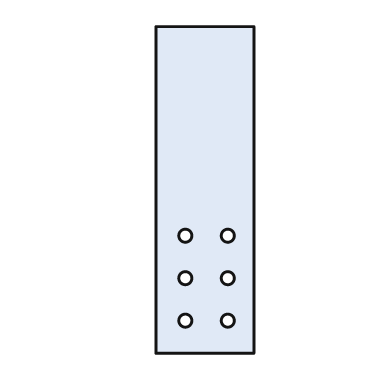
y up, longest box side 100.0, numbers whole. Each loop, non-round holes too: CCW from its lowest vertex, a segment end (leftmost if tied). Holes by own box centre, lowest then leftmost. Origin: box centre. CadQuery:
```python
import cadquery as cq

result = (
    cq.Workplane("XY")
    .moveTo(-15.0, -50.0)
    .lineTo(15.0, -50.0)
    .lineTo(15.0, 50.0)
    .lineTo(-15.0, 50.0)
    .close()
    .moveTo(-6.0, -40.0)
    .circle(2.0)
    .moveTo(7.0, -40.0)
    .circle(2.0)
    .moveTo(-6.0, -27.0)
    .circle(2.0)
    .moveTo(7.0, -27.0)
    .circle(2.0)
    .moveTo(-6.0, -14.0)
    .circle(2.0)
    .moveTo(7.0, -14.0)
    .circle(2.0)
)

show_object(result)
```